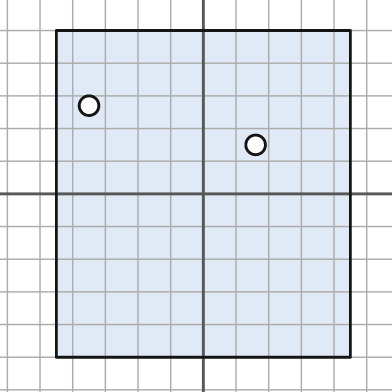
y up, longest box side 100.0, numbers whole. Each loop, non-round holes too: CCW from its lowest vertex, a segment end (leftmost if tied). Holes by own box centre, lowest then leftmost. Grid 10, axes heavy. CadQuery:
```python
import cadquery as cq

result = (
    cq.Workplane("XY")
    .moveTo(-45.0, -50.0)
    .lineTo(45.0, -50.0)
    .lineTo(45.0, 50.0)
    .lineTo(-45.0, 50.0)
    .close()
    .moveTo(16.0, 15.0)
    .circle(3.0)
    .moveTo(-35.0, 27.0)
    .circle(3.0)
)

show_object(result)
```